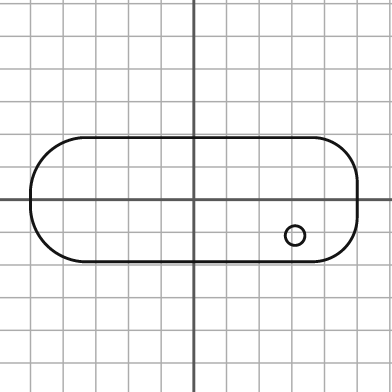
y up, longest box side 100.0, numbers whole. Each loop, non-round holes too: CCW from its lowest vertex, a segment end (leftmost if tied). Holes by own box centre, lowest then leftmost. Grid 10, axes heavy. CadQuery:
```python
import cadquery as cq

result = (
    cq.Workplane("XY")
    .moveTo(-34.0, -19.0)
    .lineTo(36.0, -19.0)
    .threePointArc((46.0, -15.0), (50.0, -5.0))
    .lineTo(50.0, 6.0)
    .threePointArc((46.0, 15.0), (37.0, 19.0))
    .lineTo(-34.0, 19.0)
    .threePointArc((-45.0, 14.0), (-50.0, 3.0))
    .lineTo(-50.0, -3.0)
    .threePointArc((-45.0, -14.0), (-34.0, -19.0))
    .close()
    .moveTo(31.0, -11.0)
    .circle(3.0)
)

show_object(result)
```